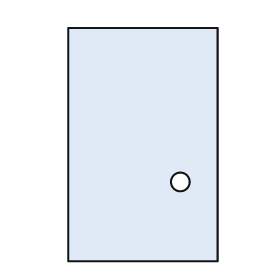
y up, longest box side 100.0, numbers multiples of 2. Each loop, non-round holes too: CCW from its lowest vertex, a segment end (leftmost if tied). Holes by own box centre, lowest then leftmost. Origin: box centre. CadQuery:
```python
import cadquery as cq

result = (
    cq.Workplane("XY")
    .moveTo(-32.0, -50.0)
    .lineTo(32.0, -50.0)
    .lineTo(32.0, 50.0)
    .lineTo(-32.0, 50.0)
    .close()
    .moveTo(16.0, -16.0)
    .circle(4.0)
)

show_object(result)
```